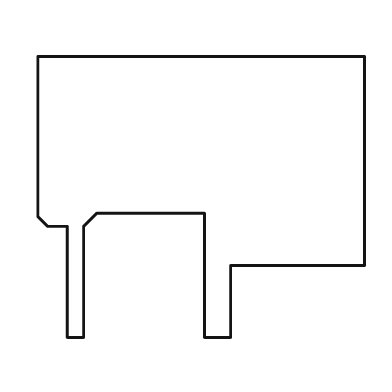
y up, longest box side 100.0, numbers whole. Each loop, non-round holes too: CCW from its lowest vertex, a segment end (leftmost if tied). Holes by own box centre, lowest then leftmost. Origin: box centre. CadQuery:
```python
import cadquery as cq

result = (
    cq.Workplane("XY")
    .moveTo(-41.0, -43.0)
    .lineTo(-36.0, -43.0)
    .lineTo(-36.0, -9.0)
    .lineTo(-32.0, -5.0)
    .lineTo(1.0, -5.0)
    .lineTo(1.0, -43.0)
    .lineTo(9.0, -43.0)
    .lineTo(9.0, -21.0)
    .lineTo(50.0, -21.0)
    .lineTo(50.0, 43.0)
    .lineTo(-50.0, 43.0)
    .lineTo(-50.0, -6.0)
    .lineTo(-47.0, -9.0)
    .lineTo(-41.0, -9.0)
    .close()
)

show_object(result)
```